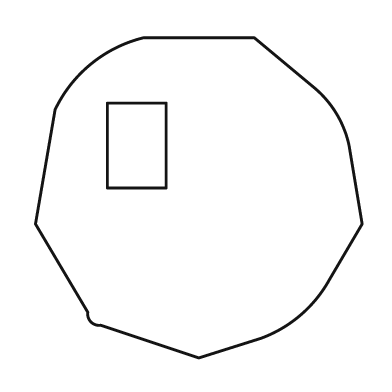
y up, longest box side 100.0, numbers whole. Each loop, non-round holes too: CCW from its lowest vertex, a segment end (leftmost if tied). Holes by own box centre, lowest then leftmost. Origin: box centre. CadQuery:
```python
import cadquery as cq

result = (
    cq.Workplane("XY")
    .moveTo(0.0, -49.0)
    .lineTo(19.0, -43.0)
    .threePointArc((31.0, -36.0), (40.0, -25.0))
    .lineTo(50.0, -8.0)
    .lineTo(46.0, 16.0)
    .threePointArc((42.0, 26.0), (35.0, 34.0))
    .lineTo(17.0, 49.0)
    .lineTo(-17.0, 49.0)
    .threePointArc((-33.0, 41.0), (-44.0, 27.0))
    .lineTo(-50.0, -8.0)
    .lineTo(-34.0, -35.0)
    .threePointArc((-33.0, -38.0), (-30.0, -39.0))
    .close()
    .moveTo(-28.0, 3.0)
    .lineTo(-10.0, 3.0)
    .lineTo(-10.0, 29.0)
    .lineTo(-28.0, 29.0)
    .close()
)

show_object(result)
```